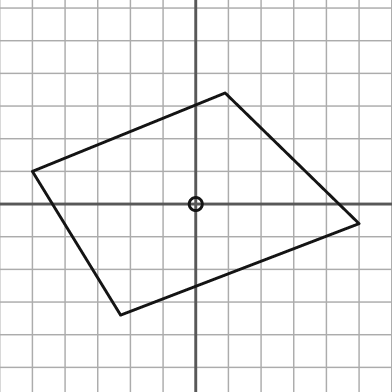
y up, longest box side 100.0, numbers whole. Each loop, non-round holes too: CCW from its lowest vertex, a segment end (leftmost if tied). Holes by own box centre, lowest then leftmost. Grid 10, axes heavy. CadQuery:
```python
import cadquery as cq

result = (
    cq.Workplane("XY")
    .moveTo(-23.0, -34.0)
    .lineTo(50.0, -6.0)
    .lineTo(9.0, 34.0)
    .lineTo(-50.0, 10.0)
    .close()
    .moveTo(0.0, 0.0)
    .circle(2.0)
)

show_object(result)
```